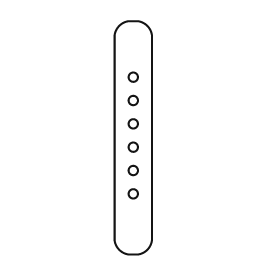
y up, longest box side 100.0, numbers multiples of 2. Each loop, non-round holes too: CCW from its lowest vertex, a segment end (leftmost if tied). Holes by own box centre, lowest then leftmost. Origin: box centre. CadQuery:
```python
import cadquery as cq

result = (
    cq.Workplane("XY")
    .moveTo(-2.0, -50.0)
    .lineTo(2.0, -50.0)
    .threePointArc((6.0, -48.0), (8.0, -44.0))
    .lineTo(8.0, 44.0)
    .threePointArc((6.0, 48.0), (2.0, 50.0))
    .lineTo(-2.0, 50.0)
    .threePointArc((-6.0, 48.0), (-8.0, 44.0))
    .lineTo(-8.0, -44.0)
    .threePointArc((-6.0, -48.0), (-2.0, -50.0))
    .close()
    .moveTo(0.0, -24.0)
    .circle(2.0)
    .moveTo(0.0, -14.0)
    .circle(2.0)
    .moveTo(0.0, -4.0)
    .circle(2.0)
    .moveTo(0.0, 6.0)
    .circle(2.0)
    .moveTo(0.0, 16.0)
    .circle(2.0)
    .moveTo(0.0, 26.0)
    .circle(2.0)
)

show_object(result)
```